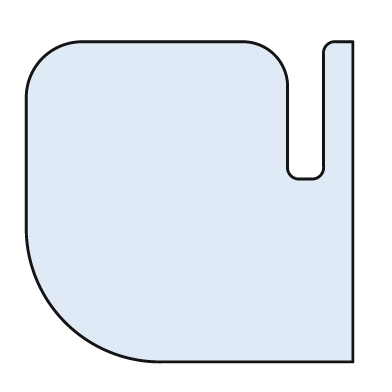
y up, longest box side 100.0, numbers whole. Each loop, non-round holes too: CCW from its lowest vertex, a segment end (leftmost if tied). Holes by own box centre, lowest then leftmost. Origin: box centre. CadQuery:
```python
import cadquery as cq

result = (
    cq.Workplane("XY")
    .moveTo(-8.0, -49.0)
    .lineTo(50.0, -49.0)
    .lineTo(50.0, 49.0)
    .lineTo(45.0, 49.0)
    .threePointArc((42.0, 48.0), (41.0, 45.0))
    .lineTo(41.0, 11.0)
    .threePointArc((40.0, 8.0), (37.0, 7.0))
    .lineTo(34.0, 7.0)
    .threePointArc((31.0, 8.0), (30.0, 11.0))
    .lineTo(30.0, 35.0)
    .threePointArc((26.0, 45.0), (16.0, 49.0))
    .lineTo(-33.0, 49.0)
    .threePointArc((-45.0, 44.0), (-50.0, 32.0))
    .lineTo(-50.0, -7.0)
    .threePointArc((-38.0, -37.0), (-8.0, -49.0))
    .close()
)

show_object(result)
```